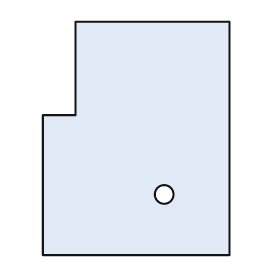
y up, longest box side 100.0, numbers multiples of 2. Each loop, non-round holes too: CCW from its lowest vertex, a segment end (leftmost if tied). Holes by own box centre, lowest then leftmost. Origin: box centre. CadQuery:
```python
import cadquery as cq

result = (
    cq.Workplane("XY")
    .moveTo(-40.0, -50.0)
    .lineTo(40.0, -50.0)
    .lineTo(40.0, 50.0)
    .lineTo(-26.0, 50.0)
    .lineTo(-26.0, 10.0)
    .lineTo(-40.0, 10.0)
    .close()
    .moveTo(12.0, -24.0)
    .circle(4.0)
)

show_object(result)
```